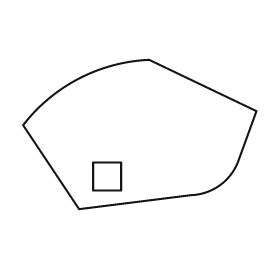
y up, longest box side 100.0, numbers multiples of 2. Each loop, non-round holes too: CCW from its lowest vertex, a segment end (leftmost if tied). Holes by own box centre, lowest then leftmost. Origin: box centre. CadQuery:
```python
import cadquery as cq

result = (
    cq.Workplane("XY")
    .moveTo(-26.0, -32.0)
    .lineTo(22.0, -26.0)
    .threePointArc((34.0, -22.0), (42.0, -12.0))
    .lineTo(50.0, 10.0)
    .lineTo(4.0, 32.0)
    .threePointArc((-26.0, 24.0), (-50.0, 4.0))
    .close()
    .moveTo(-20.0, -24.0)
    .lineTo(-8.0, -24.0)
    .lineTo(-8.0, -12.0)
    .lineTo(-20.0, -12.0)
    .close()
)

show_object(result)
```